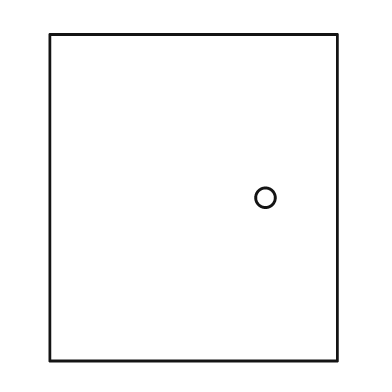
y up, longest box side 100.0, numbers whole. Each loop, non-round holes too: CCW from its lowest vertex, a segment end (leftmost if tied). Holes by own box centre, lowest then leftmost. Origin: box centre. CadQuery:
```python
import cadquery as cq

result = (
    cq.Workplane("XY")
    .moveTo(-44.0, -50.0)
    .lineTo(44.0, -50.0)
    .lineTo(44.0, 50.0)
    .lineTo(-44.0, 50.0)
    .close()
    .moveTo(22.0, 0.0)
    .circle(3.0)
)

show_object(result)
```